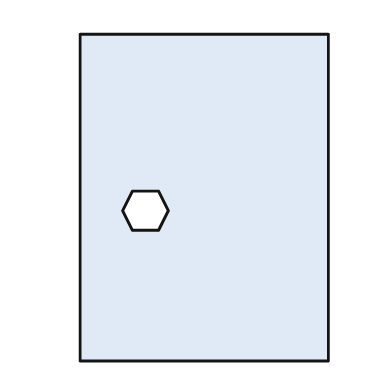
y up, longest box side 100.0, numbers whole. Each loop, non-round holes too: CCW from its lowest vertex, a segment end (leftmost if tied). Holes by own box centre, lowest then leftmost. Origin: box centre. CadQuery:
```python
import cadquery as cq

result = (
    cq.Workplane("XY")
    .moveTo(-38.0, -50.0)
    .lineTo(38.0, -50.0)
    .lineTo(38.0, 50.0)
    .lineTo(-38.0, 50.0)
    .close()
    .moveTo(-22.0, -10.0)
    .lineTo(-14.0, -10.0)
    .lineTo(-11.0, -4.0)
    .lineTo(-14.0, 2.0)
    .lineTo(-22.0, 2.0)
    .lineTo(-25.0, -4.0)
    .close()
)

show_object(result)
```